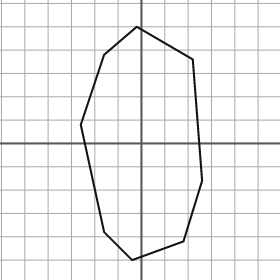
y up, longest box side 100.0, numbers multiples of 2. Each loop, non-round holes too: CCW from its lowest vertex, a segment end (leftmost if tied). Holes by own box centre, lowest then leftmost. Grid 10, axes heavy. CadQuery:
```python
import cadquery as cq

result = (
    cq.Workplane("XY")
    .moveTo(-4.0, -50.0)
    .lineTo(18.0, -42.0)
    .lineTo(26.0, -16.0)
    .lineTo(22.0, 36.0)
    .lineTo(-2.0, 50.0)
    .lineTo(-16.0, 38.0)
    .lineTo(-26.0, 8.0)
    .lineTo(-16.0, -38.0)
    .close()
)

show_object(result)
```